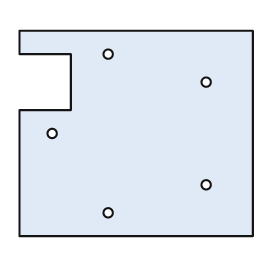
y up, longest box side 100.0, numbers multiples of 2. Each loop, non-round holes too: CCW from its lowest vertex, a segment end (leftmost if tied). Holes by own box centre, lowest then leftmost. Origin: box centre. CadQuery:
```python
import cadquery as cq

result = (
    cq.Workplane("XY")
    .moveTo(-50.0, -44.0)
    .lineTo(50.0, -44.0)
    .lineTo(50.0, 44.0)
    .lineTo(-50.0, 44.0)
    .lineTo(-50.0, 34.0)
    .lineTo(-28.0, 34.0)
    .lineTo(-28.0, 10.0)
    .lineTo(-50.0, 10.0)
    .close()
    .moveTo(-12.0, -34.0)
    .circle(2.0)
    .moveTo(30.0, -22.0)
    .circle(2.0)
    .moveTo(-36.0, 0.0)
    .circle(2.0)
    .moveTo(30.0, 22.0)
    .circle(2.0)
    .moveTo(-12.0, 34.0)
    .circle(2.0)
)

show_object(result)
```